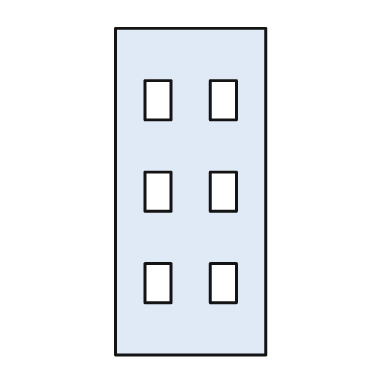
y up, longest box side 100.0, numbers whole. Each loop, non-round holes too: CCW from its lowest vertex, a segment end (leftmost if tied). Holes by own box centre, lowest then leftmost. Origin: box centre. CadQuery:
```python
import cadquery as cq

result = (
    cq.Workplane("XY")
    .moveTo(-23.0, -50.0)
    .lineTo(23.0, -50.0)
    .lineTo(23.0, 50.0)
    .lineTo(-23.0, 50.0)
    .close()
    .moveTo(-14.0, -34.0)
    .lineTo(-6.0, -34.0)
    .lineTo(-6.0, -22.0)
    .lineTo(-14.0, -22.0)
    .close()
    .moveTo(6.0, -34.0)
    .lineTo(14.0, -34.0)
    .lineTo(14.0, -22.0)
    .lineTo(6.0, -22.0)
    .close()
    .moveTo(-14.0, -6.0)
    .lineTo(-6.0, -6.0)
    .lineTo(-6.0, 6.0)
    .lineTo(-14.0, 6.0)
    .close()
    .moveTo(6.0, -6.0)
    .lineTo(14.0, -6.0)
    .lineTo(14.0, 6.0)
    .lineTo(6.0, 6.0)
    .close()
    .moveTo(-14.0, 22.0)
    .lineTo(-6.0, 22.0)
    .lineTo(-6.0, 34.0)
    .lineTo(-14.0, 34.0)
    .close()
    .moveTo(6.0, 22.0)
    .lineTo(14.0, 22.0)
    .lineTo(14.0, 34.0)
    .lineTo(6.0, 34.0)
    .close()
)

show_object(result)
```